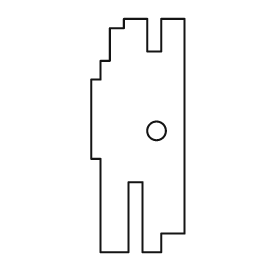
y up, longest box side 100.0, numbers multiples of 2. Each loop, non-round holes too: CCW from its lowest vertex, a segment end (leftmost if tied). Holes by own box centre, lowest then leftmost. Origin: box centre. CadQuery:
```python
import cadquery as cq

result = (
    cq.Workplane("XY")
    .moveTo(-16.0, -50.0)
    .lineTo(-4.0, -50.0)
    .lineTo(-4.0, -20.0)
    .lineTo(2.0, -20.0)
    .lineTo(2.0, -50.0)
    .lineTo(10.0, -50.0)
    .lineTo(10.0, -42.0)
    .lineTo(20.0, -42.0)
    .lineTo(20.0, 50.0)
    .lineTo(10.0, 50.0)
    .lineTo(10.0, 36.0)
    .lineTo(4.0, 36.0)
    .lineTo(4.0, 50.0)
    .lineTo(-6.0, 50.0)
    .lineTo(-6.0, 46.0)
    .lineTo(-12.0, 46.0)
    .lineTo(-12.0, 32.0)
    .lineTo(-16.0, 32.0)
    .lineTo(-16.0, 24.0)
    .lineTo(-20.0, 24.0)
    .lineTo(-20.0, -10.0)
    .lineTo(-16.0, -10.0)
    .close()
    .moveTo(8.0, 2.0)
    .circle(4.0)
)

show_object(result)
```